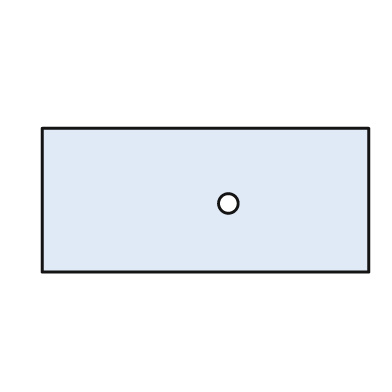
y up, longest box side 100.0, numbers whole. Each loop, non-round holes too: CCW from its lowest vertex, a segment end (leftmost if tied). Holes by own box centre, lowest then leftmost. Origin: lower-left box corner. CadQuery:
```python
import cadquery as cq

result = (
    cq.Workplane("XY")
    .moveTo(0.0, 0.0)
    .lineTo(100.0, 0.0)
    .lineTo(100.0, 44.0)
    .lineTo(0.0, 44.0)
    .close()
    .moveTo(57.0, 21.0)
    .circle(3.0)
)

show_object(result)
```